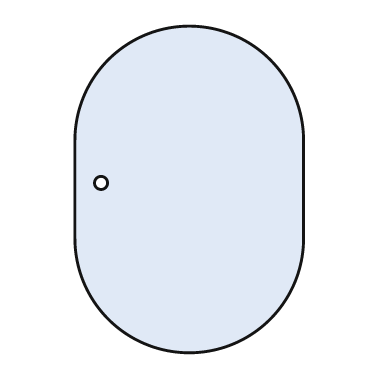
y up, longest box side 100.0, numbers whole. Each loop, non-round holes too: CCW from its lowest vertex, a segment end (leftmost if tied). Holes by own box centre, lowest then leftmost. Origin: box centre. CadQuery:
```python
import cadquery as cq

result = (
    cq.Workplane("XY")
    .moveTo(-35.0, -15.0)
    .threePointArc((0.0, -50.0), (35.0, -15.0))
    .lineTo(35.0, 15.0)
    .threePointArc((0.0, 50.0), (-35.0, 15.0))
    .close()
    .moveTo(-27.0, 2.0)
    .circle(2.0)
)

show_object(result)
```